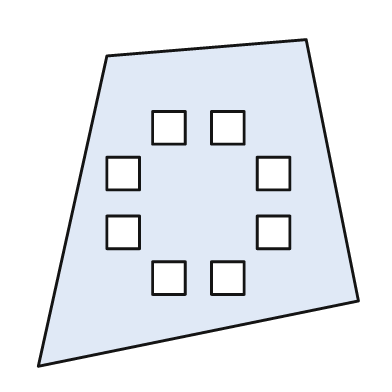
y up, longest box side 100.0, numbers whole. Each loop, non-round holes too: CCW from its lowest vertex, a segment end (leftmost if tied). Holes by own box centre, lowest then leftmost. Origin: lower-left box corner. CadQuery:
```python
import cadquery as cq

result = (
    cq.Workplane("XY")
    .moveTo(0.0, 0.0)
    .lineTo(98.0, 20.0)
    .lineTo(82.0, 100.0)
    .lineTo(21.0, 95.0)
    .close()
    .moveTo(35.0, 22.0)
    .lineTo(45.0, 22.0)
    .lineTo(45.0, 32.0)
    .lineTo(35.0, 32.0)
    .close()
    .moveTo(53.0, 22.0)
    .lineTo(63.0, 22.0)
    .lineTo(63.0, 32.0)
    .lineTo(53.0, 32.0)
    .close()
    .moveTo(21.0, 36.0)
    .lineTo(31.0, 36.0)
    .lineTo(31.0, 46.0)
    .lineTo(21.0, 46.0)
    .close()
    .moveTo(67.0, 36.0)
    .lineTo(77.0, 36.0)
    .lineTo(77.0, 46.0)
    .lineTo(67.0, 46.0)
    .close()
    .moveTo(21.0, 54.0)
    .lineTo(31.0, 54.0)
    .lineTo(31.0, 64.0)
    .lineTo(21.0, 64.0)
    .close()
    .moveTo(67.0, 54.0)
    .lineTo(77.0, 54.0)
    .lineTo(77.0, 64.0)
    .lineTo(67.0, 64.0)
    .close()
    .moveTo(35.0, 68.0)
    .lineTo(45.0, 68.0)
    .lineTo(45.0, 78.0)
    .lineTo(35.0, 78.0)
    .close()
    .moveTo(53.0, 68.0)
    .lineTo(63.0, 68.0)
    .lineTo(63.0, 78.0)
    .lineTo(53.0, 78.0)
    .close()
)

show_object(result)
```